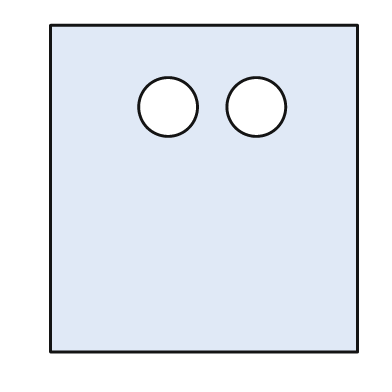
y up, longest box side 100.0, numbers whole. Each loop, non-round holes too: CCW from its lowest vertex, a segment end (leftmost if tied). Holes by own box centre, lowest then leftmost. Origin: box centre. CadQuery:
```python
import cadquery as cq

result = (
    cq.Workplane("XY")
    .moveTo(-47.0, -50.0)
    .lineTo(47.0, -50.0)
    .lineTo(47.0, 50.0)
    .lineTo(-47.0, 50.0)
    .close()
    .moveTo(-11.0, 25.0)
    .circle(9.0)
    .moveTo(16.0, 25.0)
    .circle(9.0)
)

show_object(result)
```